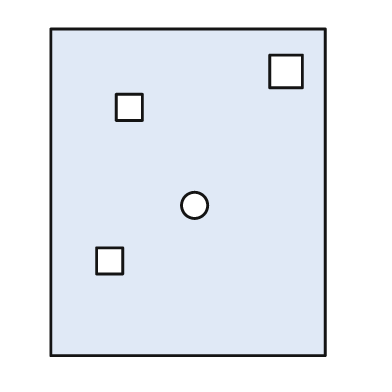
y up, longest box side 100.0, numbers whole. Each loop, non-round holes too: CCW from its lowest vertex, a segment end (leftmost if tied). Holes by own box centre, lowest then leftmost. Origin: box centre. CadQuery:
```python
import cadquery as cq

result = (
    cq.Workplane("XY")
    .moveTo(-42.0, -50.0)
    .lineTo(42.0, -50.0)
    .lineTo(42.0, 50.0)
    .lineTo(-42.0, 50.0)
    .close()
    .moveTo(-28.0, -25.0)
    .lineTo(-20.0, -25.0)
    .lineTo(-20.0, -17.0)
    .lineTo(-28.0, -17.0)
    .close()
    .moveTo(2.0, -4.0)
    .circle(4.0)
    .moveTo(-22.0, 22.0)
    .lineTo(-14.0, 22.0)
    .lineTo(-14.0, 30.0)
    .lineTo(-22.0, 30.0)
    .close()
    .moveTo(25.0, 32.0)
    .lineTo(35.0, 32.0)
    .lineTo(35.0, 42.0)
    .lineTo(25.0, 42.0)
    .close()
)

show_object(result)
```